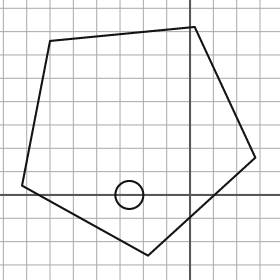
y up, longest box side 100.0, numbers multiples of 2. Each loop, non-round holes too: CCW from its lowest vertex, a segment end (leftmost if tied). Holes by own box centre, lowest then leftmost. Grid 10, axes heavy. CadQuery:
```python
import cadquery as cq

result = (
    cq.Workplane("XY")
    .moveTo(-18.0, -26.0)
    .lineTo(28.0, 16.0)
    .lineTo(2.0, 72.0)
    .lineTo(-60.0, 66.0)
    .lineTo(-72.0, 4.0)
    .close()
    .moveTo(-26.0, 0.0)
    .circle(6.0)
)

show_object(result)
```